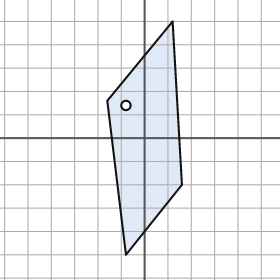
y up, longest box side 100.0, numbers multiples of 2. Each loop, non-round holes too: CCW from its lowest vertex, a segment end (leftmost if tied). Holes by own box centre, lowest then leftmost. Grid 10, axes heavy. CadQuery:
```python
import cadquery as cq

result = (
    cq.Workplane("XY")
    .moveTo(-8.0, -50.0)
    .lineTo(16.0, -20.0)
    .lineTo(12.0, 50.0)
    .lineTo(-16.0, 16.0)
    .close()
    .moveTo(-8.0, 14.0)
    .circle(2.0)
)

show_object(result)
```